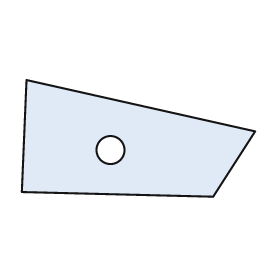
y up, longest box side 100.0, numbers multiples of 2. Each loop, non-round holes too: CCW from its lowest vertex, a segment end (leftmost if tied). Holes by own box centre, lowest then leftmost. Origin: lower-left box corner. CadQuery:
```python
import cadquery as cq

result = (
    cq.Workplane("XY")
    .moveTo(82.0, 0.0)
    .lineTo(100.0, 28.0)
    .lineTo(2.0, 50.0)
    .lineTo(0.0, 2.0)
    .close()
    .moveTo(38.0, 20.0)
    .circle(6.0)
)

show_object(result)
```